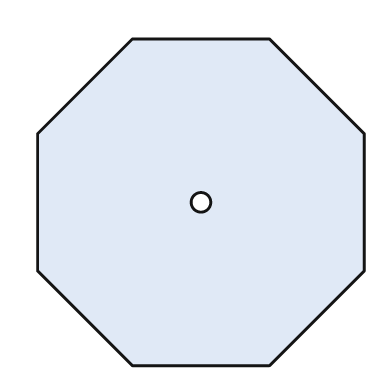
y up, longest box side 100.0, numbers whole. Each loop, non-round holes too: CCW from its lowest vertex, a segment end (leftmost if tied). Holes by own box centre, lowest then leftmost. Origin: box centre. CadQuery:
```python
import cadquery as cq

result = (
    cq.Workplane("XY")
    .moveTo(-21.0, -50.0)
    .lineTo(21.0, -50.0)
    .lineTo(50.0, -21.0)
    .lineTo(50.0, 21.0)
    .lineTo(21.0, 50.0)
    .lineTo(-21.0, 50.0)
    .lineTo(-50.0, 21.0)
    .lineTo(-50.0, -21.0)
    .close()
    .moveTo(0.0, 0.0)
    .circle(3.0)
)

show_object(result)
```